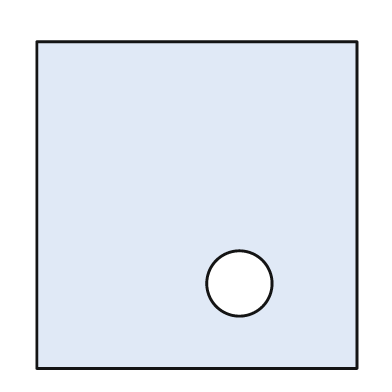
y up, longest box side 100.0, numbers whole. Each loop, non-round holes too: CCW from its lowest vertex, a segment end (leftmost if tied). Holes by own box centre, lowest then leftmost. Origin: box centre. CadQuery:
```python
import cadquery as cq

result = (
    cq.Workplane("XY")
    .moveTo(-49.0, -50.0)
    .lineTo(49.0, -50.0)
    .lineTo(49.0, 50.0)
    .lineTo(-49.0, 50.0)
    .close()
    .moveTo(13.0, -24.0)
    .circle(10.0)
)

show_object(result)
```